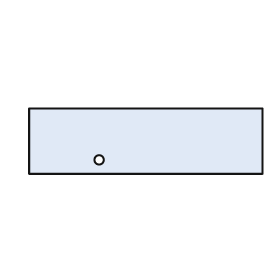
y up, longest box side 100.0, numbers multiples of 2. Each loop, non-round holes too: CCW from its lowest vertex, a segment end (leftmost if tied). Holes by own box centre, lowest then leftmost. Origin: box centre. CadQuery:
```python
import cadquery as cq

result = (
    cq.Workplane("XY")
    .moveTo(-50.0, -14.0)
    .lineTo(50.0, -14.0)
    .lineTo(50.0, 14.0)
    .lineTo(-50.0, 14.0)
    .close()
    .moveTo(-20.0, -8.0)
    .circle(2.0)
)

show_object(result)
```